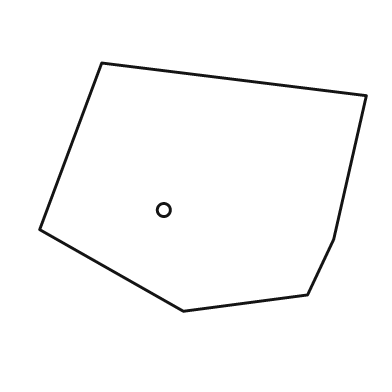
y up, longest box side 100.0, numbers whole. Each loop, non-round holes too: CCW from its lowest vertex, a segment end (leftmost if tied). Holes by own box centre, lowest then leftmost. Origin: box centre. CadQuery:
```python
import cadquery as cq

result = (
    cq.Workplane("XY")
    .moveTo(-6.0, -38.0)
    .lineTo(32.0, -33.0)
    .lineTo(40.0, -16.0)
    .lineTo(50.0, 28.0)
    .lineTo(-31.0, 38.0)
    .lineTo(-50.0, -13.0)
    .close()
    .moveTo(-12.0, -7.0)
    .circle(2.0)
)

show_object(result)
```